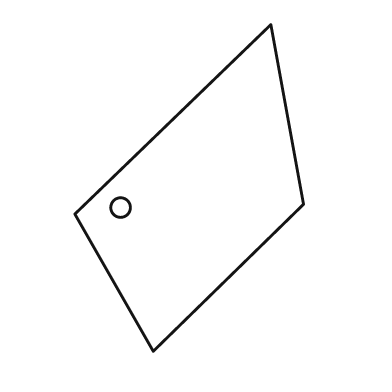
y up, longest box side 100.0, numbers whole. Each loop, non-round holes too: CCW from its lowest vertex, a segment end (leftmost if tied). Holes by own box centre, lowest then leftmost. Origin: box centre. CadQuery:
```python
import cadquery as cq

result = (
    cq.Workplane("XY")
    .moveTo(-11.0, -50.0)
    .lineTo(35.0, -5.0)
    .lineTo(25.0, 50.0)
    .lineTo(-35.0, -8.0)
    .close()
    .moveTo(-21.0, -6.0)
    .circle(3.0)
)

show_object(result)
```